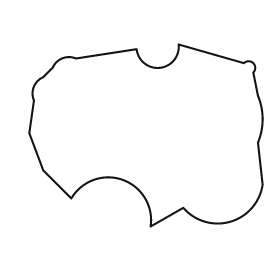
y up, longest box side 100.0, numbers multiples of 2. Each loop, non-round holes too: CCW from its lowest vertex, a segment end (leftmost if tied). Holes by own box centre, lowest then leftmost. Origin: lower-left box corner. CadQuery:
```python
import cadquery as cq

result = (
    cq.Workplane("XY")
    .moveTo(52.0, 0.0)
    .lineTo(66.0, 8.0)
    .threePointArc((86.0, 2.0), (100.0, 18.0))
    .lineTo(98.0, 36.0)
    .threePointArc((100.0, 46.0), (98.0, 56.0))
    .lineTo(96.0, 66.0)
    .threePointArc((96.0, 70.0), (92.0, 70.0))
    .lineTo(64.0, 78.0)
    .threePointArc((56.0, 68.0), (46.0, 76.0))
    .lineTo(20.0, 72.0)
    .threePointArc((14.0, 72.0), (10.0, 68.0))
    .lineTo(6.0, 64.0)
    .threePointArc((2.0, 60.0), (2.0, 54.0))
    .lineTo(0.0, 40.0)
    .lineTo(6.0, 24.0)
    .lineTo(18.0, 12.0)
    .threePointArc((40.0, 20.0), (52.0, 0.0))
    .close()
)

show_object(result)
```